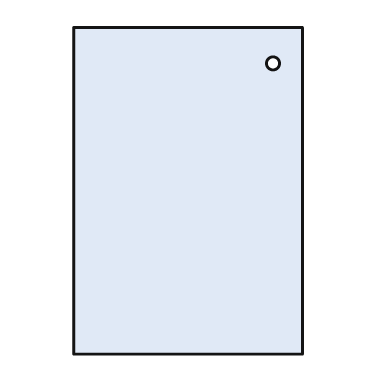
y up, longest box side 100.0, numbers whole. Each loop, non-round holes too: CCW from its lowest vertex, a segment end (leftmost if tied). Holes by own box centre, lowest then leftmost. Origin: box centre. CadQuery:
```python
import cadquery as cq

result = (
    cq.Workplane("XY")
    .moveTo(-35.0, -50.0)
    .lineTo(35.0, -50.0)
    .lineTo(35.0, 50.0)
    .lineTo(-35.0, 50.0)
    .close()
    .moveTo(26.0, 39.0)
    .circle(2.0)
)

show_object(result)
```